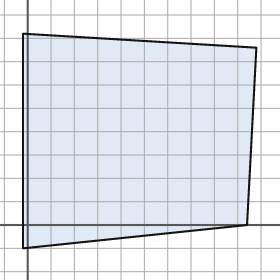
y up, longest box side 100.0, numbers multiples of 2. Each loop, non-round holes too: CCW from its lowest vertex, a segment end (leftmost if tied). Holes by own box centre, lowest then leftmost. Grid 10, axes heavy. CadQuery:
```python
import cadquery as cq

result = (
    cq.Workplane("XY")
    .moveTo(-2.0, -10.0)
    .lineTo(94.0, 0.0)
    .lineTo(98.0, 76.0)
    .lineTo(-2.0, 82.0)
    .close()
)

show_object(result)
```